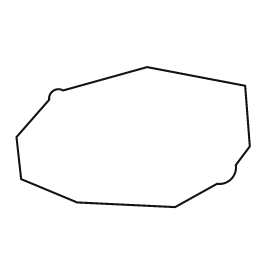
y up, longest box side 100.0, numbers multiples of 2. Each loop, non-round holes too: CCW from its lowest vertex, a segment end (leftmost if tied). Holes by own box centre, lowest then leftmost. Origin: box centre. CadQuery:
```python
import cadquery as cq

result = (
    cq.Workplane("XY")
    .moveTo(18.0, -30.0)
    .lineTo(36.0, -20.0)
    .threePointArc((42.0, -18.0), (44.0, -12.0))
    .lineTo(50.0, -4.0)
    .lineTo(48.0, 22.0)
    .lineTo(6.0, 30.0)
    .lineTo(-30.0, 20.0)
    .threePointArc((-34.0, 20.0), (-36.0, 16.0))
    .lineTo(-50.0, 0.0)
    .lineTo(-48.0, -18.0)
    .lineTo(-24.0, -28.0)
    .close()
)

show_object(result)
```